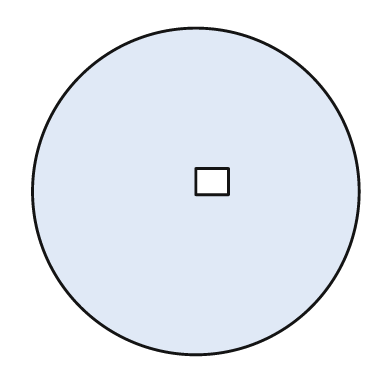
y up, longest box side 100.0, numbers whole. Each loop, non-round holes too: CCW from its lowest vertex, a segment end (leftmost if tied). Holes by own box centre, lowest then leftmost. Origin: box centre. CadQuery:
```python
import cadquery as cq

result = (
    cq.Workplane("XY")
    .moveTo(0.0, 0.0)
    .circle(50.0)
    .moveTo(0.0, -1.0)
    .lineTo(10.0, -1.0)
    .lineTo(10.0, 7.0)
    .lineTo(0.0, 7.0)
    .close()
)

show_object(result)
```